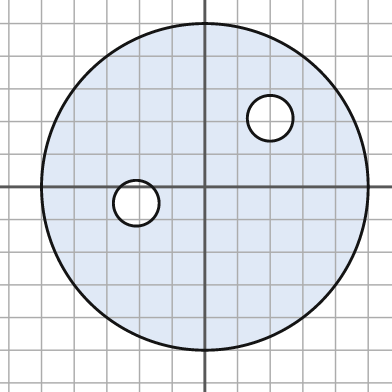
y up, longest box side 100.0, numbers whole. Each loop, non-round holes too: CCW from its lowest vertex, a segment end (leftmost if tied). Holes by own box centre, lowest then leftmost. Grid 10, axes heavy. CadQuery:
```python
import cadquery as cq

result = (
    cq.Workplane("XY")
    .moveTo(0.0, 0.0)
    .circle(50.0)
    .moveTo(-21.0, -5.0)
    .circle(7.0)
    .moveTo(20.0, 21.0)
    .circle(7.0)
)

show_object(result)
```